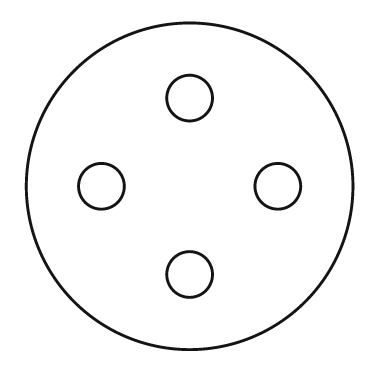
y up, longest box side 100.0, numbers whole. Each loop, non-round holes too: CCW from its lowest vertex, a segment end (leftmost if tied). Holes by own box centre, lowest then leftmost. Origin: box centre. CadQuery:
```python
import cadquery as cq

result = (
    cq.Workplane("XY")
    .moveTo(0.0, 0.0)
    .circle(50.0)
    .moveTo(0.0, -27.0)
    .circle(7.0)
    .moveTo(-27.0, 0.0)
    .circle(7.0)
    .moveTo(27.0, 0.0)
    .circle(7.0)
    .moveTo(0.0, 27.0)
    .circle(7.0)
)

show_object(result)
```